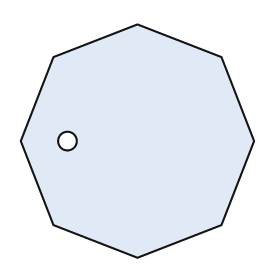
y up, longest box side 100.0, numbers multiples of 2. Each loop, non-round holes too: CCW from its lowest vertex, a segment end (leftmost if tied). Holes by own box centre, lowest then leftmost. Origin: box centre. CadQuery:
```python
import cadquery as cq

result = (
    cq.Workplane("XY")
    .moveTo(0.0, -50.0)
    .lineTo(36.0, -36.0)
    .lineTo(50.0, 0.0)
    .lineTo(36.0, 36.0)
    .lineTo(0.0, 50.0)
    .lineTo(-36.0, 36.0)
    .lineTo(-50.0, 0.0)
    .lineTo(-36.0, -36.0)
    .close()
    .moveTo(-30.0, 0.0)
    .circle(4.0)
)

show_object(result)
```